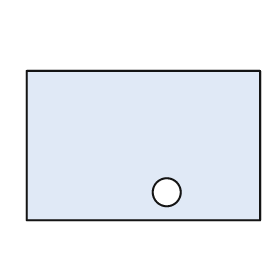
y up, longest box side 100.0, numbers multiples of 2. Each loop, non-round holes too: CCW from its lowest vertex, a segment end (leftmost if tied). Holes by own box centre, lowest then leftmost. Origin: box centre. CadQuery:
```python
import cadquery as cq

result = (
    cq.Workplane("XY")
    .moveTo(-50.0, -32.0)
    .lineTo(50.0, -32.0)
    .lineTo(50.0, 32.0)
    .lineTo(-50.0, 32.0)
    .close()
    .moveTo(10.0, -20.0)
    .circle(6.0)
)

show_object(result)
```